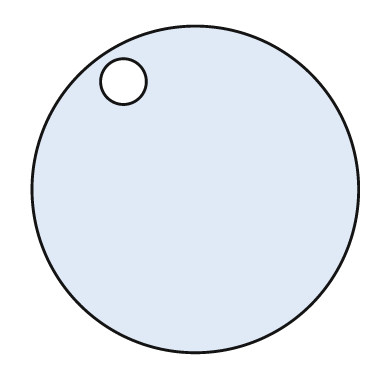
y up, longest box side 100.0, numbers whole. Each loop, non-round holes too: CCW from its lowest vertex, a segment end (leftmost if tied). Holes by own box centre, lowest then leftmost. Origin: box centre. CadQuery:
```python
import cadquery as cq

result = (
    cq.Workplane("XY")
    .moveTo(0.0, 0.0)
    .circle(50.0)
    .moveTo(-22.0, 33.0)
    .circle(7.0)
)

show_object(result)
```